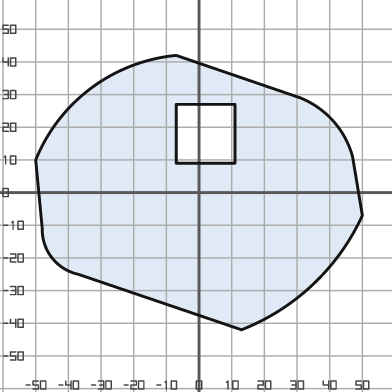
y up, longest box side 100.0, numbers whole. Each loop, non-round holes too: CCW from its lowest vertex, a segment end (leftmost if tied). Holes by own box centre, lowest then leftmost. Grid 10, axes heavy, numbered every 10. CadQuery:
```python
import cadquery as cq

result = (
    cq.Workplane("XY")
    .moveTo(13.0, -42.0)
    .threePointArc((35.0, -28.0), (50.0, -7.0))
    .lineTo(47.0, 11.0)
    .threePointArc((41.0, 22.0), (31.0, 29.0))
    .lineTo(-7.0, 42.0)
    .threePointArc((-33.0, 32.0), (-50.0, 10.0))
    .lineTo(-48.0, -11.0)
    .threePointArc((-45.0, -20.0), (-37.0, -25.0))
    .close()
    .moveTo(-7.0, 9.0)
    .lineTo(11.0, 9.0)
    .lineTo(11.0, 27.0)
    .lineTo(-7.0, 27.0)
    .close()
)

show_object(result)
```